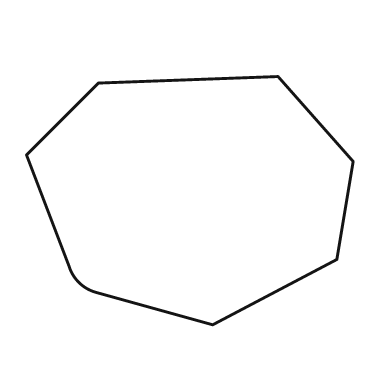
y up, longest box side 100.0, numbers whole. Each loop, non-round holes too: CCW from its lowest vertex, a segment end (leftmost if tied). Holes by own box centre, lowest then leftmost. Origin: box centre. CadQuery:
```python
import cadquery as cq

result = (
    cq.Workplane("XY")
    .moveTo(7.0, -38.0)
    .lineTo(45.0, -18.0)
    .lineTo(50.0, 12.0)
    .lineTo(27.0, 38.0)
    .lineTo(-28.0, 36.0)
    .lineTo(-50.0, 14.0)
    .lineTo(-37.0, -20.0)
    .threePointArc((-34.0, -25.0), (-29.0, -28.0))
    .close()
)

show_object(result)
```